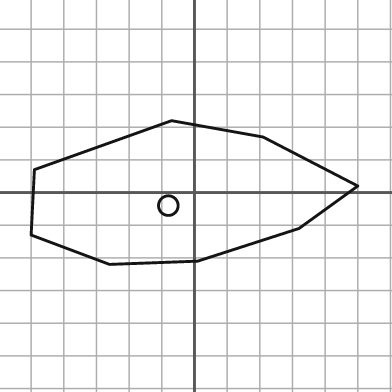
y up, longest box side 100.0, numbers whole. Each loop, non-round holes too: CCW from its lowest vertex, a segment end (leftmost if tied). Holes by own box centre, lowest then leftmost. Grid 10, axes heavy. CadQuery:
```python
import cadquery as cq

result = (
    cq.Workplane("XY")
    .moveTo(-26.0, -22.0)
    .lineTo(1.0, -21.0)
    .lineTo(32.0, -11.0)
    .lineTo(50.0, 2.0)
    .lineTo(21.0, 17.0)
    .lineTo(-7.0, 22.0)
    .lineTo(-49.0, 7.0)
    .lineTo(-50.0, -13.0)
    .close()
    .moveTo(-8.0, -4.0)
    .circle(3.0)
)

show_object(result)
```